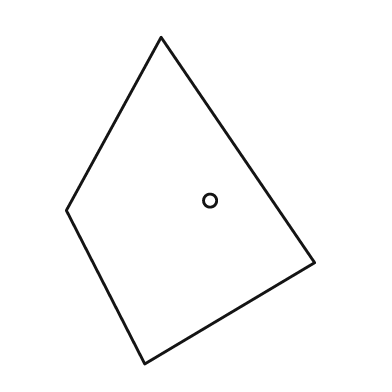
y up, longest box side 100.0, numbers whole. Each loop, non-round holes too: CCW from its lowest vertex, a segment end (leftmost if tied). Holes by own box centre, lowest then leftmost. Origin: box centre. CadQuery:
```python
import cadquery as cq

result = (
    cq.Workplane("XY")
    .moveTo(-14.0, -50.0)
    .lineTo(38.0, -19.0)
    .lineTo(-9.0, 50.0)
    .lineTo(-38.0, -3.0)
    .close()
    .moveTo(6.0, 0.0)
    .circle(2.0)
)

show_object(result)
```